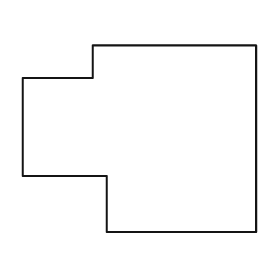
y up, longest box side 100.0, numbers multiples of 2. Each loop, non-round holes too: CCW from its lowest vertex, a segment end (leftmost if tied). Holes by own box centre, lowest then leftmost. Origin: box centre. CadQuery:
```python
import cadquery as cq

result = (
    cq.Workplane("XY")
    .moveTo(-14.0, -40.0)
    .lineTo(50.0, -40.0)
    .lineTo(50.0, 40.0)
    .lineTo(-20.0, 40.0)
    .lineTo(-20.0, 26.0)
    .lineTo(-50.0, 26.0)
    .lineTo(-50.0, -16.0)
    .lineTo(-14.0, -16.0)
    .close()
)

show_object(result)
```